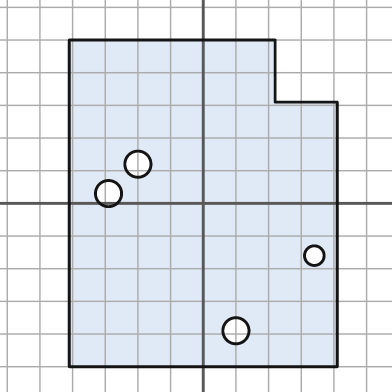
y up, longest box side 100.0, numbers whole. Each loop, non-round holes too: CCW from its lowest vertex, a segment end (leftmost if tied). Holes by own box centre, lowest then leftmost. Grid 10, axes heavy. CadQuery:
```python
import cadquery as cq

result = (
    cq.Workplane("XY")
    .moveTo(-41.0, -50.0)
    .lineTo(41.0, -50.0)
    .lineTo(41.0, 31.0)
    .lineTo(22.0, 31.0)
    .lineTo(22.0, 50.0)
    .lineTo(-41.0, 50.0)
    .close()
    .moveTo(10.0, -39.0)
    .circle(4.0)
    .moveTo(34.0, -16.0)
    .circle(3.0)
    .moveTo(-29.0, 3.0)
    .circle(4.0)
    .moveTo(-20.0, 12.0)
    .circle(4.0)
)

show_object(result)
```